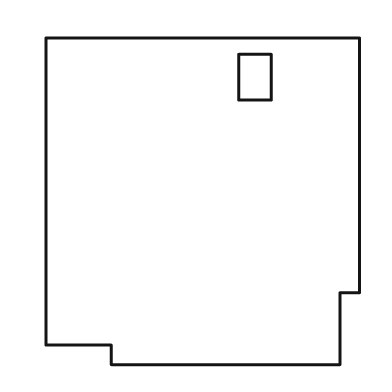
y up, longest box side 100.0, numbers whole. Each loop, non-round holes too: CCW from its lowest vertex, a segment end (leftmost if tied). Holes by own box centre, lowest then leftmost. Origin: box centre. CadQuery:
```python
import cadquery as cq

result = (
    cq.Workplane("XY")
    .moveTo(-28.0, -50.0)
    .lineTo(42.0, -50.0)
    .lineTo(42.0, -28.0)
    .lineTo(48.0, -28.0)
    .lineTo(48.0, 50.0)
    .lineTo(-48.0, 50.0)
    .lineTo(-48.0, -44.0)
    .lineTo(-28.0, -44.0)
    .close()
    .moveTo(11.0, 31.0)
    .lineTo(21.0, 31.0)
    .lineTo(21.0, 45.0)
    .lineTo(11.0, 45.0)
    .close()
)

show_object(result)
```